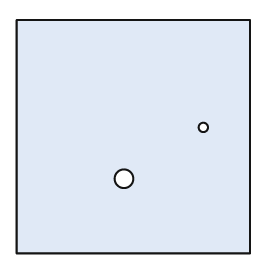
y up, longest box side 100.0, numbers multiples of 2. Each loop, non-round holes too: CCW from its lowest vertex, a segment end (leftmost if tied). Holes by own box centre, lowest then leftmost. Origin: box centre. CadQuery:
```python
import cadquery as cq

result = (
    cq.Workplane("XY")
    .moveTo(-50.0, -50.0)
    .lineTo(50.0, -50.0)
    .lineTo(50.0, 50.0)
    .lineTo(-50.0, 50.0)
    .close()
    .moveTo(-4.0, -18.0)
    .circle(4.0)
    .moveTo(30.0, 4.0)
    .circle(2.0)
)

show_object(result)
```